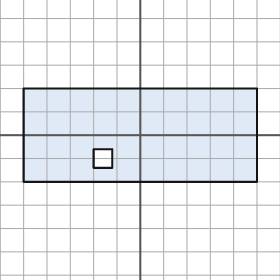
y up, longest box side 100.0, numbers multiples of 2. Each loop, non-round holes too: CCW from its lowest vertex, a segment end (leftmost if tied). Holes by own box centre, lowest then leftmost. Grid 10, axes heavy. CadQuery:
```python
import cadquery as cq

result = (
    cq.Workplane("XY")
    .moveTo(-50.0, -20.0)
    .lineTo(50.0, -20.0)
    .lineTo(50.0, 20.0)
    .lineTo(-50.0, 20.0)
    .close()
    .moveTo(-20.0, -14.0)
    .lineTo(-12.0, -14.0)
    .lineTo(-12.0, -6.0)
    .lineTo(-20.0, -6.0)
    .close()
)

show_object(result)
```